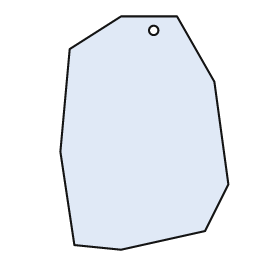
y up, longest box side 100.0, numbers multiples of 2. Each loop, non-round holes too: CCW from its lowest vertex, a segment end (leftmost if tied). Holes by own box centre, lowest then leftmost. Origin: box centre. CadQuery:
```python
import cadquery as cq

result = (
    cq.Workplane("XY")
    .moveTo(-10.0, -50.0)
    .lineTo(26.0, -42.0)
    .lineTo(36.0, -22.0)
    .lineTo(30.0, 22.0)
    .lineTo(14.0, 50.0)
    .lineTo(-10.0, 50.0)
    .lineTo(-32.0, 36.0)
    .lineTo(-36.0, -8.0)
    .lineTo(-30.0, -48.0)
    .close()
    .moveTo(4.0, 44.0)
    .circle(2.0)
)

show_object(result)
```